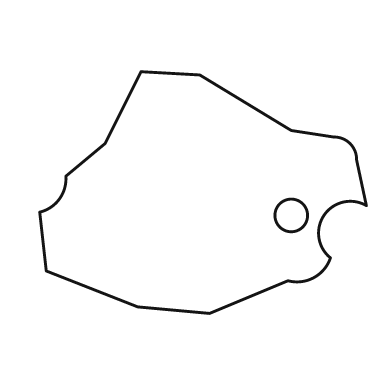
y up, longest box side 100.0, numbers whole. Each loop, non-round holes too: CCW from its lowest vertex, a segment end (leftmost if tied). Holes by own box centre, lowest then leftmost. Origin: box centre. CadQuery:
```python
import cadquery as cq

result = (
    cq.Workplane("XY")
    .moveTo(2.0, -37.0)
    .lineTo(26.0, -27.0)
    .threePointArc((34.0, -26.0), (39.0, -20.0))
    .threePointArc((37.0, -7.0), (50.0, -4.0))
    .lineTo(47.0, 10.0)
    .threePointArc((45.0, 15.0), (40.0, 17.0))
    .lineTo(27.0, 19.0)
    .lineTo(-1.0, 36.0)
    .lineTo(-19.0, 37.0)
    .lineTo(-30.0, 15.0)
    .lineTo(-42.0, 5.0)
    .threePointArc((-44.0, -2.0), (-50.0, -6.0))
    .lineTo(-48.0, -24.0)
    .lineTo(-20.0, -35.0)
    .close()
    .moveTo(27.0, -7.0)
    .circle(5.0)
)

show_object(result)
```